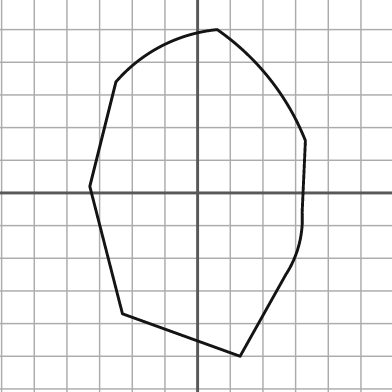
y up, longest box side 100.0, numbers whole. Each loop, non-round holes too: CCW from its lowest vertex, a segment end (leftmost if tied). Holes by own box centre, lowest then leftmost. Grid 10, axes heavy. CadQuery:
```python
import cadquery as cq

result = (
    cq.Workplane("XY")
    .moveTo(13.0, -50.0)
    .lineTo(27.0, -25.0)
    .threePointArc((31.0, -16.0), (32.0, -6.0))
    .lineTo(33.0, 16.0)
    .threePointArc((22.0, 35.0), (6.0, 50.0))
    .threePointArc((-11.0, 45.0), (-25.0, 34.0))
    .lineTo(-33.0, 2.0)
    .lineTo(-23.0, -37.0)
    .close()
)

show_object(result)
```